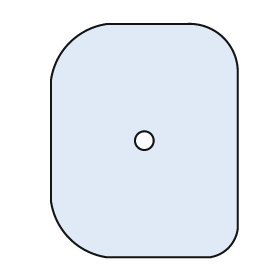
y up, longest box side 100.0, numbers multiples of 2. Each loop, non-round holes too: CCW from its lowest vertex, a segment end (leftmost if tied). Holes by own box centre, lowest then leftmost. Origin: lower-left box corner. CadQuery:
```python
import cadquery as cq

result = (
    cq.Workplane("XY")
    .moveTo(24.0, 0.0)
    .lineTo(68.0, 0.0)
    .threePointArc((76.0, 4.0), (80.0, 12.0))
    .lineTo(80.0, 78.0)
    .threePointArc((74.0, 94.0), (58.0, 100.0))
    .lineTo(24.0, 100.0)
    .threePointArc((8.0, 92.0), (0.0, 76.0))
    .lineTo(0.0, 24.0)
    .threePointArc((8.0, 8.0), (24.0, 0.0))
    .close()
    .moveTo(40.0, 50.0)
    .circle(4.0)
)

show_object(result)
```